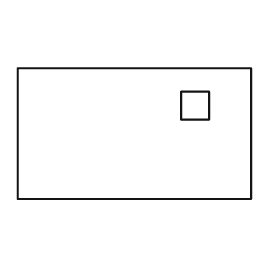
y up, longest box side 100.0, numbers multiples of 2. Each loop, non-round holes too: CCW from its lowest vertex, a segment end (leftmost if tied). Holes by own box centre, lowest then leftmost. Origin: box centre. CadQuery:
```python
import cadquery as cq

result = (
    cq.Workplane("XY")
    .moveTo(-50.0, -28.0)
    .lineTo(50.0, -28.0)
    .lineTo(50.0, 28.0)
    .lineTo(-50.0, 28.0)
    .close()
    .moveTo(20.0, 6.0)
    .lineTo(32.0, 6.0)
    .lineTo(32.0, 18.0)
    .lineTo(20.0, 18.0)
    .close()
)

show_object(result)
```